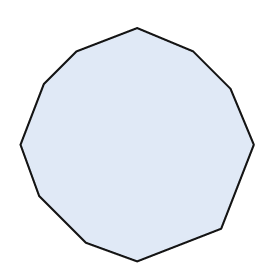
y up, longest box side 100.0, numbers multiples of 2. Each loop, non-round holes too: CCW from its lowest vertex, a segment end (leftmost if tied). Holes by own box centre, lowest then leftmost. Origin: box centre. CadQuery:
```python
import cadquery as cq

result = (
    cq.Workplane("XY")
    .moveTo(0.0, -50.0)
    .lineTo(36.0, -36.0)
    .lineTo(50.0, 0.0)
    .lineTo(40.0, 24.0)
    .lineTo(24.0, 40.0)
    .lineTo(0.0, 50.0)
    .lineTo(-26.0, 40.0)
    .lineTo(-40.0, 26.0)
    .lineTo(-50.0, 0.0)
    .lineTo(-42.0, -22.0)
    .lineTo(-22.0, -42.0)
    .close()
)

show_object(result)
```